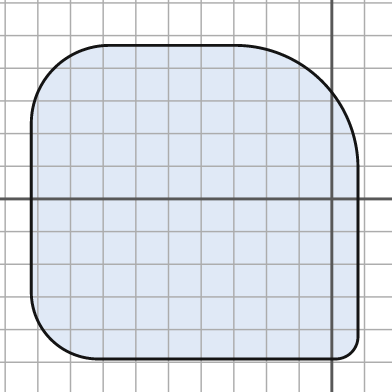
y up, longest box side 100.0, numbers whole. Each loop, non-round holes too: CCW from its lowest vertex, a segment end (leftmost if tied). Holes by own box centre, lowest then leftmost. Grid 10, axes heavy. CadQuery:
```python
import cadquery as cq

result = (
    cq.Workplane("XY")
    .moveTo(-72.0, -49.0)
    .lineTo(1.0, -49.0)
    .threePointArc((6.0, -47.0), (8.0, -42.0))
    .lineTo(8.0, 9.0)
    .threePointArc((-3.0, 36.0), (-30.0, 47.0))
    .lineTo(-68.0, 47.0)
    .threePointArc((-85.0, 40.0), (-92.0, 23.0))
    .lineTo(-92.0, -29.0)
    .threePointArc((-86.0, -43.0), (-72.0, -49.0))
    .close()
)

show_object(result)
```